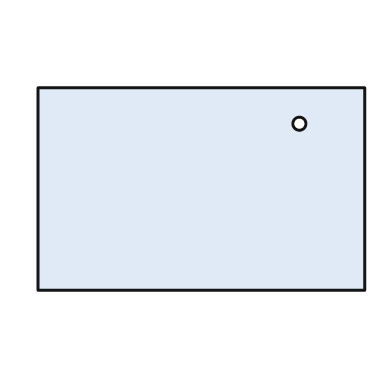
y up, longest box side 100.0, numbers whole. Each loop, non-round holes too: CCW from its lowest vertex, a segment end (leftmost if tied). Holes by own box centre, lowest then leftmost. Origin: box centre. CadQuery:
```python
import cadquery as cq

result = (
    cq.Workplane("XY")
    .moveTo(-50.0, -31.0)
    .lineTo(50.0, -31.0)
    .lineTo(50.0, 31.0)
    .lineTo(-50.0, 31.0)
    .close()
    .moveTo(30.0, 20.0)
    .circle(2.0)
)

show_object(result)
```